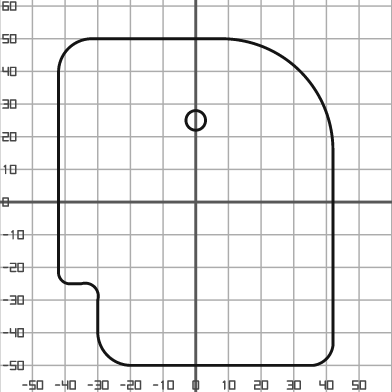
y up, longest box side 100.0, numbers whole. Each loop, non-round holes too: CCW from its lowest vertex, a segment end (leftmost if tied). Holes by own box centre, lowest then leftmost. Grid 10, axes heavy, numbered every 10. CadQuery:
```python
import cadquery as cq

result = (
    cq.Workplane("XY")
    .moveTo(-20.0, -50.0)
    .lineTo(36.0, -50.0)
    .threePointArc((40.0, -48.0), (42.0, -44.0))
    .lineTo(42.0, 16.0)
    .threePointArc((32.0, 40.0), (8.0, 50.0))
    .lineTo(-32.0, 50.0)
    .threePointArc((-39.0, 47.0), (-42.0, 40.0))
    .lineTo(-42.0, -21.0)
    .threePointArc((-41.0, -24.0), (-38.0, -25.0))
    .lineTo(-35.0, -25.0)
    .threePointArc((-31.0, -26.0), (-30.0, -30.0))
    .lineTo(-30.0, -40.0)
    .threePointArc((-27.0, -47.0), (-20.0, -50.0))
    .close()
    .moveTo(0.0, 25.0)
    .circle(3.0)
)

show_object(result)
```